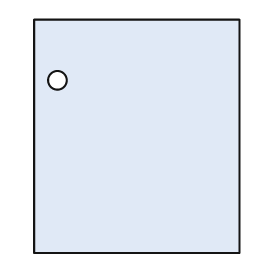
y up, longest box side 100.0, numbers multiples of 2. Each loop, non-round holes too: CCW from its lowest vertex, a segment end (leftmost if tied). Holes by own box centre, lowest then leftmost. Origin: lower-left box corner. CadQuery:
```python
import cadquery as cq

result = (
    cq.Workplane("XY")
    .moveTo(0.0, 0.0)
    .lineTo(88.0, 0.0)
    .lineTo(88.0, 100.0)
    .lineTo(0.0, 100.0)
    .close()
    .moveTo(10.0, 74.0)
    .circle(4.0)
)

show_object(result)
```